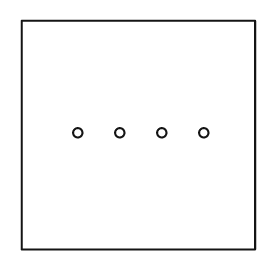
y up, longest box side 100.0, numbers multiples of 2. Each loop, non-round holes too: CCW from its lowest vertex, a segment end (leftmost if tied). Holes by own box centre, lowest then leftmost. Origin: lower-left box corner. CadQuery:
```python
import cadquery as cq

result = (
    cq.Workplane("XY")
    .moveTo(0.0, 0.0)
    .lineTo(100.0, 0.0)
    .lineTo(100.0, 98.0)
    .lineTo(0.0, 98.0)
    .close()
    .moveTo(24.0, 50.0)
    .circle(2.0)
    .moveTo(42.0, 50.0)
    .circle(2.0)
    .moveTo(60.0, 50.0)
    .circle(2.0)
    .moveTo(78.0, 50.0)
    .circle(2.0)
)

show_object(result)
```